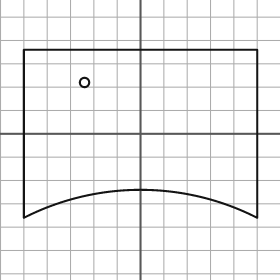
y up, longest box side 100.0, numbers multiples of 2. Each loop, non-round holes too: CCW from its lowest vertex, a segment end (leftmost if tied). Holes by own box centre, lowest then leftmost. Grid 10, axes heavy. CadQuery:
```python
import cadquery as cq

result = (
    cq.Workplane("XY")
    .moveTo(-50.0, -36.0)
    .threePointArc((0.0, -24.0), (50.0, -36.0))
    .lineTo(50.0, 36.0)
    .lineTo(-50.0, 36.0)
    .close()
    .moveTo(-24.0, 22.0)
    .circle(2.0)
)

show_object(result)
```